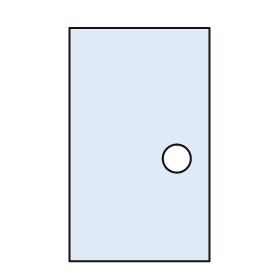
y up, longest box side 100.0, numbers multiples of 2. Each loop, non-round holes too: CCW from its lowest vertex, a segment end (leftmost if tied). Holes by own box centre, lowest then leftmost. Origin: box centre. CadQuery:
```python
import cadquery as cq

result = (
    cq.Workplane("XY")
    .moveTo(-30.0, -50.0)
    .lineTo(30.0, -50.0)
    .lineTo(30.0, 50.0)
    .lineTo(-30.0, 50.0)
    .close()
    .moveTo(16.0, -6.0)
    .circle(6.0)
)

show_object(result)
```